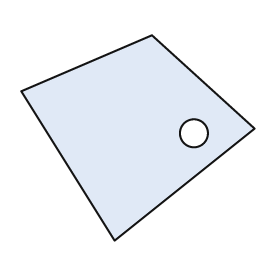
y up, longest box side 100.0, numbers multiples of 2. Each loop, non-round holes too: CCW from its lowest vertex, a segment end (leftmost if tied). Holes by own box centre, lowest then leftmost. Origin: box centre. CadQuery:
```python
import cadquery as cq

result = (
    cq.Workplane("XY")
    .moveTo(-10.0, -44.0)
    .lineTo(50.0, 4.0)
    .lineTo(6.0, 44.0)
    .lineTo(-50.0, 20.0)
    .close()
    .moveTo(24.0, 2.0)
    .circle(6.0)
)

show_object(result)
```